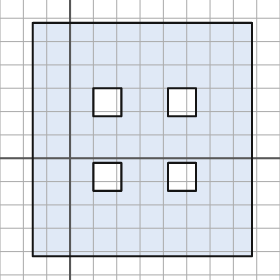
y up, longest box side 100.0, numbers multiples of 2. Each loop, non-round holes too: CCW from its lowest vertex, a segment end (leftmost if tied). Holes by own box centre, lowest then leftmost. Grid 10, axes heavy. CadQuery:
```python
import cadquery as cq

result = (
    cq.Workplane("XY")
    .moveTo(-16.0, -42.0)
    .lineTo(78.0, -42.0)
    .lineTo(78.0, 58.0)
    .lineTo(-16.0, 58.0)
    .close()
    .moveTo(10.0, -14.0)
    .lineTo(22.0, -14.0)
    .lineTo(22.0, -2.0)
    .lineTo(10.0, -2.0)
    .close()
    .moveTo(42.0, -14.0)
    .lineTo(54.0, -14.0)
    .lineTo(54.0, -2.0)
    .lineTo(42.0, -2.0)
    .close()
    .moveTo(10.0, 18.0)
    .lineTo(22.0, 18.0)
    .lineTo(22.0, 30.0)
    .lineTo(10.0, 30.0)
    .close()
    .moveTo(42.0, 18.0)
    .lineTo(54.0, 18.0)
    .lineTo(54.0, 30.0)
    .lineTo(42.0, 30.0)
    .close()
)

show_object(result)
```